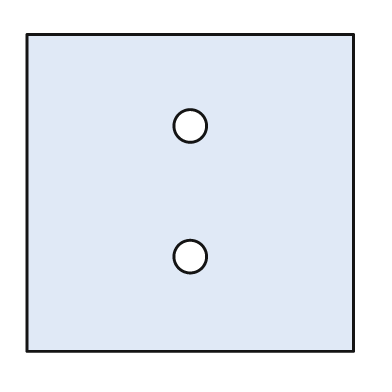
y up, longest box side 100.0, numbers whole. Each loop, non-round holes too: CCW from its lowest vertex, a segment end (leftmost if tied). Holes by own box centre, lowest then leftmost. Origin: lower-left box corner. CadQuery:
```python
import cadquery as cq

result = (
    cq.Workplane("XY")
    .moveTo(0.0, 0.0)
    .lineTo(100.0, 0.0)
    .lineTo(100.0, 97.0)
    .lineTo(0.0, 97.0)
    .close()
    .moveTo(50.0, 29.0)
    .circle(5.0)
    .moveTo(50.0, 69.0)
    .circle(5.0)
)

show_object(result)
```